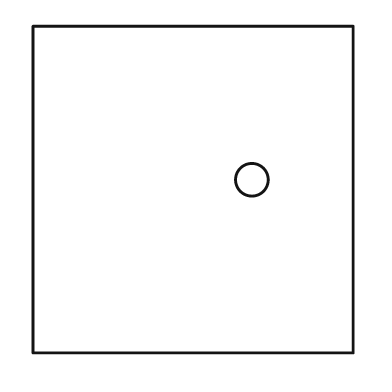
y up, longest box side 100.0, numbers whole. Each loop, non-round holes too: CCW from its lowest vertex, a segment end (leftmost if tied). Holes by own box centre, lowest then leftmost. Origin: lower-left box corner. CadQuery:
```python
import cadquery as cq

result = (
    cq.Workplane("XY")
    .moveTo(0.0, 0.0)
    .lineTo(98.0, 0.0)
    .lineTo(98.0, 100.0)
    .lineTo(0.0, 100.0)
    .close()
    .moveTo(67.0, 53.0)
    .circle(5.0)
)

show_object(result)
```